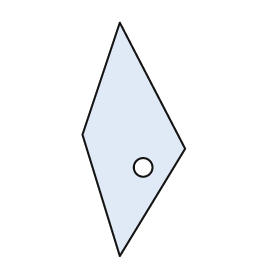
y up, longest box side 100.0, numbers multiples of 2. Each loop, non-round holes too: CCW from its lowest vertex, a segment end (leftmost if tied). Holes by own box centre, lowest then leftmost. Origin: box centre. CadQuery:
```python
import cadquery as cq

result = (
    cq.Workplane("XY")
    .moveTo(-6.0, -50.0)
    .lineTo(22.0, -4.0)
    .lineTo(-6.0, 50.0)
    .lineTo(-22.0, 2.0)
    .close()
    .moveTo(4.0, -12.0)
    .circle(4.0)
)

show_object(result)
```